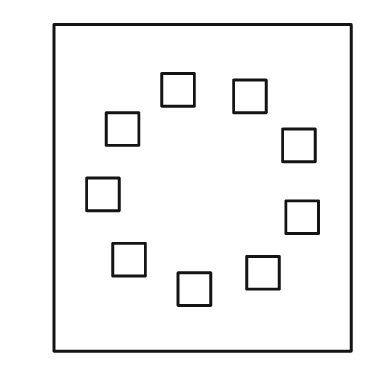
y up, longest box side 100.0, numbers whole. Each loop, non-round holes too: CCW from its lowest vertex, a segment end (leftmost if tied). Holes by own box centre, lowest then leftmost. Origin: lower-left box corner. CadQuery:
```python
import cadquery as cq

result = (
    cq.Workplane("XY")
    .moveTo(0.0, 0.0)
    .lineTo(91.0, 0.0)
    .lineTo(91.0, 100.0)
    .lineTo(0.0, 100.0)
    .close()
    .moveTo(38.0, 14.0)
    .lineTo(48.0, 14.0)
    .lineTo(48.0, 24.0)
    .lineTo(38.0, 24.0)
    .close()
    .moveTo(59.0, 19.0)
    .lineTo(69.0, 19.0)
    .lineTo(69.0, 29.0)
    .lineTo(59.0, 29.0)
    .close()
    .moveTo(18.0, 23.0)
    .lineTo(28.0, 23.0)
    .lineTo(28.0, 33.0)
    .lineTo(18.0, 33.0)
    .close()
    .moveTo(71.0, 36.0)
    .lineTo(81.0, 36.0)
    .lineTo(81.0, 46.0)
    .lineTo(71.0, 46.0)
    .close()
    .moveTo(10.0, 43.0)
    .lineTo(20.0, 43.0)
    .lineTo(20.0, 53.0)
    .lineTo(10.0, 53.0)
    .close()
    .moveTo(70.0, 58.0)
    .lineTo(80.0, 58.0)
    .lineTo(80.0, 68.0)
    .lineTo(70.0, 68.0)
    .close()
    .moveTo(16.0, 63.0)
    .lineTo(26.0, 63.0)
    .lineTo(26.0, 73.0)
    .lineTo(16.0, 73.0)
    .close()
    .moveTo(55.0, 73.0)
    .lineTo(65.0, 73.0)
    .lineTo(65.0, 83.0)
    .lineTo(55.0, 83.0)
    .close()
    .moveTo(33.0, 75.0)
    .lineTo(43.0, 75.0)
    .lineTo(43.0, 85.0)
    .lineTo(33.0, 85.0)
    .close()
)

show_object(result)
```